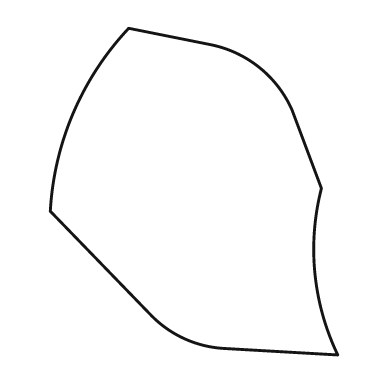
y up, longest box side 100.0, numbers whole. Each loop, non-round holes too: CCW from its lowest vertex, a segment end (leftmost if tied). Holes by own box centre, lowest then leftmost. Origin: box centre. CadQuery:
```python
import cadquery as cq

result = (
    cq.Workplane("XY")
    .moveTo(44.0, -50.0)
    .threePointArc((37.0, -25.0), (39.0, 1.0))
    .lineTo(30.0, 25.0)
    .threePointArc((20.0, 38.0), (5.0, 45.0))
    .lineTo(-20.0, 50.0)
    .threePointArc((-37.0, 24.0), (-44.0, -6.0))
    .lineTo(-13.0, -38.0)
    .threePointArc((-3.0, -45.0), (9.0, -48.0))
    .close()
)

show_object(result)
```